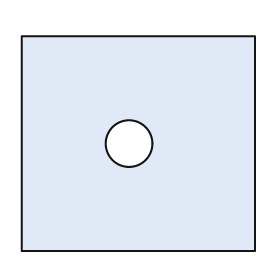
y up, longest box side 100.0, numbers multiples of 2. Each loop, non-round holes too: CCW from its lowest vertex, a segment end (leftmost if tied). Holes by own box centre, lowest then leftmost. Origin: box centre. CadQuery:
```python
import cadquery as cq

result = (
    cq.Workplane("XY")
    .moveTo(-50.0, -46.0)
    .lineTo(50.0, -46.0)
    .lineTo(50.0, 46.0)
    .lineTo(-50.0, 46.0)
    .close()
    .moveTo(-4.0, 0.0)
    .circle(10.0)
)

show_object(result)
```